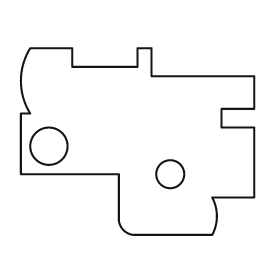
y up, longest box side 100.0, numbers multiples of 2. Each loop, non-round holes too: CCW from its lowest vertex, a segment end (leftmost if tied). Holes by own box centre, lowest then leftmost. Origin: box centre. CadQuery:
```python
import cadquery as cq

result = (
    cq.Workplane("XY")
    .moveTo(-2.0, -40.0)
    .lineTo(32.0, -40.0)
    .threePointArc((34.0, -32.0), (32.0, -24.0))
    .lineTo(50.0, -24.0)
    .lineTo(50.0, 6.0)
    .lineTo(36.0, 6.0)
    .lineTo(36.0, 14.0)
    .lineTo(50.0, 14.0)
    .lineTo(50.0, 28.0)
    .lineTo(6.0, 28.0)
    .lineTo(6.0, 40.0)
    .lineTo(0.0, 40.0)
    .lineTo(0.0, 32.0)
    .lineTo(-28.0, 32.0)
    .lineTo(-28.0, 40.0)
    .lineTo(-46.0, 40.0)
    .threePointArc((-50.0, 26.0), (-46.0, 12.0))
    .lineTo(-50.0, 12.0)
    .lineTo(-50.0, -14.0)
    .lineTo(-8.0, -14.0)
    .lineTo(-8.0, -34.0)
    .threePointArc((-6.0, -38.0), (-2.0, -40.0))
    .close()
    .moveTo(14.0, -14.0)
    .circle(6.0)
    .moveTo(-38.0, -2.0)
    .circle(8.0)
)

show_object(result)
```